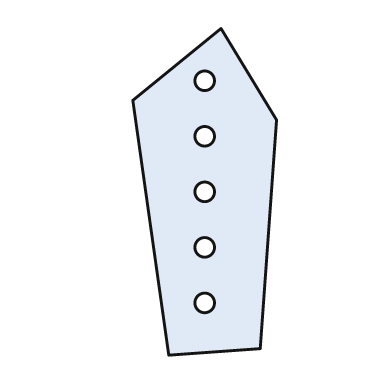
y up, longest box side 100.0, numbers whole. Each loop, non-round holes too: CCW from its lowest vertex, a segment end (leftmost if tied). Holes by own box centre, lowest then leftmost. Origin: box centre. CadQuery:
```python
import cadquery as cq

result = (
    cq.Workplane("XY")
    .moveTo(-11.0, -50.0)
    .lineTo(17.0, -48.0)
    .lineTo(22.0, 22.0)
    .lineTo(5.0, 50.0)
    .lineTo(-22.0, 28.0)
    .close()
    .moveTo(0.0, -34.0)
    .circle(3.0)
    .moveTo(0.0, -17.0)
    .circle(3.0)
    .moveTo(0.0, 0.0)
    .circle(3.0)
    .moveTo(0.0, 17.0)
    .circle(3.0)
    .moveTo(0.0, 34.0)
    .circle(3.0)
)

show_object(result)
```